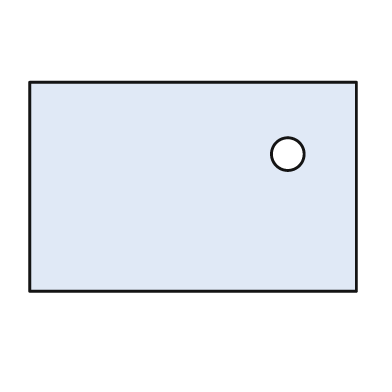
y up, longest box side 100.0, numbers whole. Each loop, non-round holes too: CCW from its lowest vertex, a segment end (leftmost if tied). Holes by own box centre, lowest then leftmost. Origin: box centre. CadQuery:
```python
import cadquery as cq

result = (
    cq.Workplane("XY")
    .moveTo(-50.0, -32.0)
    .lineTo(50.0, -32.0)
    .lineTo(50.0, 32.0)
    .lineTo(-50.0, 32.0)
    .close()
    .moveTo(29.0, 10.0)
    .circle(5.0)
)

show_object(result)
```